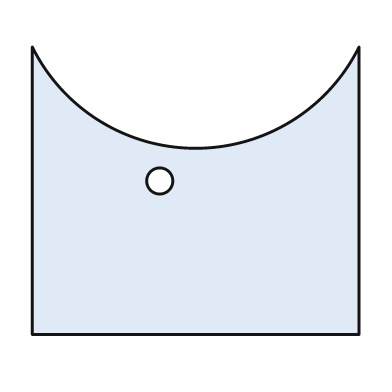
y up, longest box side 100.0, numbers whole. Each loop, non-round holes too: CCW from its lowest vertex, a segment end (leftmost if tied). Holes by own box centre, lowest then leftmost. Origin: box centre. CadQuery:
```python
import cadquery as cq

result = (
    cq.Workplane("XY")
    .moveTo(-50.0, -44.0)
    .lineTo(50.0, -44.0)
    .lineTo(50.0, 44.0)
    .threePointArc((0.0, 13.0), (-50.0, 44.0))
    .close()
    .moveTo(-11.0, 3.0)
    .circle(4.0)
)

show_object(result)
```